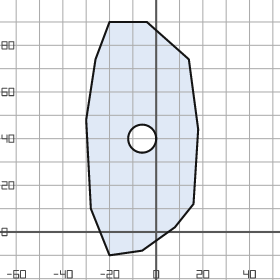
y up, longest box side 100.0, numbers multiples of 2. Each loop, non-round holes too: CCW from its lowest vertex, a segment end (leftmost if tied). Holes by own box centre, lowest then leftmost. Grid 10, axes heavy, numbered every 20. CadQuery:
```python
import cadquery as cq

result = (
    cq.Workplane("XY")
    .moveTo(-20.0, -10.0)
    .lineTo(-6.0, -8.0)
    .lineTo(8.0, 2.0)
    .lineTo(16.0, 12.0)
    .lineTo(18.0, 44.0)
    .lineTo(14.0, 74.0)
    .lineTo(-4.0, 90.0)
    .lineTo(-20.0, 90.0)
    .lineTo(-26.0, 74.0)
    .lineTo(-30.0, 48.0)
    .lineTo(-28.0, 10.0)
    .close()
    .moveTo(-6.0, 40.0)
    .circle(6.0)
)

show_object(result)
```